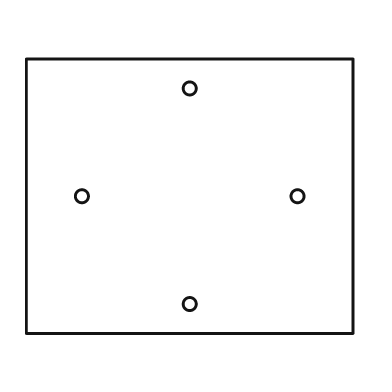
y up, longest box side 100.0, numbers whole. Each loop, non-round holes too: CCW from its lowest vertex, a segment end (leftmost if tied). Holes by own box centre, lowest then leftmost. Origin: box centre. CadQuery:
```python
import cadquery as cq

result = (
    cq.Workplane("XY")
    .moveTo(-50.0, -42.0)
    .lineTo(50.0, -42.0)
    .lineTo(50.0, 42.0)
    .lineTo(-50.0, 42.0)
    .close()
    .moveTo(0.0, -33.0)
    .circle(2.0)
    .moveTo(-33.0, 0.0)
    .circle(2.0)
    .moveTo(33.0, 0.0)
    .circle(2.0)
    .moveTo(0.0, 33.0)
    .circle(2.0)
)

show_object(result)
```